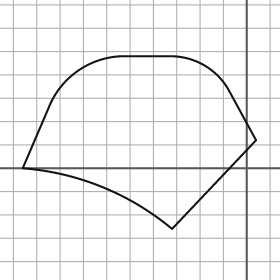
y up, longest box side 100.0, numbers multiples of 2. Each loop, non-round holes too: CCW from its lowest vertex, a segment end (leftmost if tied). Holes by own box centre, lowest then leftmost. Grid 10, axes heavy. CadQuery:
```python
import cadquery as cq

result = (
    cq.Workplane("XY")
    .moveTo(-32.0, -26.0)
    .lineTo(4.0, 12.0)
    .lineTo(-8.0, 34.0)
    .threePointArc((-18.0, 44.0), (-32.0, 48.0))
    .lineTo(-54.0, 48.0)
    .threePointArc((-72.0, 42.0), (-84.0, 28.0))
    .lineTo(-96.0, 0.0)
    .threePointArc((-62.0, -8.0), (-32.0, -26.0))
    .close()
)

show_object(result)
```